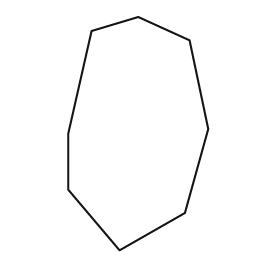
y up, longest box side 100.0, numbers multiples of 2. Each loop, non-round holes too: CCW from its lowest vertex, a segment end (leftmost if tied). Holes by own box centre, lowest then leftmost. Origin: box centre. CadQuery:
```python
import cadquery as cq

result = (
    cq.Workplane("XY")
    .moveTo(-8.0, -50.0)
    .lineTo(20.0, -34.0)
    .lineTo(30.0, 2.0)
    .lineTo(22.0, 40.0)
    .lineTo(0.0, 50.0)
    .lineTo(-20.0, 44.0)
    .lineTo(-30.0, 0.0)
    .lineTo(-30.0, -24.0)
    .close()
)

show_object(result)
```